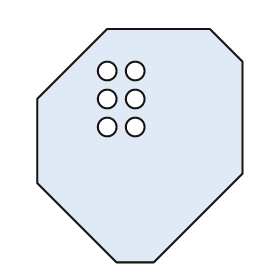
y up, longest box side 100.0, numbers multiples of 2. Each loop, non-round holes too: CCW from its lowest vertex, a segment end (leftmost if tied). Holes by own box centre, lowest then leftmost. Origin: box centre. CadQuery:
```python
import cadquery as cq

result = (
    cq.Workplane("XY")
    .moveTo(-10.0, -50.0)
    .lineTo(6.0, -50.0)
    .lineTo(44.0, -12.0)
    .lineTo(44.0, 36.0)
    .lineTo(30.0, 50.0)
    .lineTo(-14.0, 50.0)
    .lineTo(-44.0, 20.0)
    .lineTo(-44.0, -16.0)
    .close()
    .moveTo(-14.0, 8.0)
    .circle(4.0)
    .moveTo(-2.0, 8.0)
    .circle(4.0)
    .moveTo(-14.0, 20.0)
    .circle(4.0)
    .moveTo(-2.0, 20.0)
    .circle(4.0)
    .moveTo(-14.0, 32.0)
    .circle(4.0)
    .moveTo(-2.0, 32.0)
    .circle(4.0)
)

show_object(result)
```